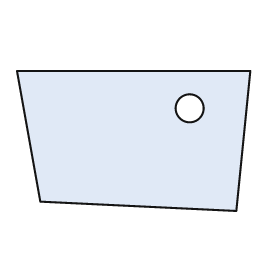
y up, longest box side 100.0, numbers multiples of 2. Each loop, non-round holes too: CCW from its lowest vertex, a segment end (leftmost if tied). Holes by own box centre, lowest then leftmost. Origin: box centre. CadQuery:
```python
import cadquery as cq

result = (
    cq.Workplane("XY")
    .moveTo(44.0, -30.0)
    .lineTo(50.0, 30.0)
    .lineTo(-50.0, 30.0)
    .lineTo(-40.0, -26.0)
    .close()
    .moveTo(24.0, 14.0)
    .circle(6.0)
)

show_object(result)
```